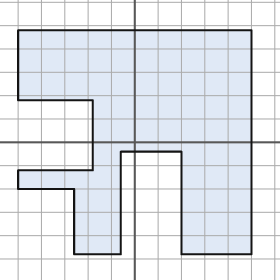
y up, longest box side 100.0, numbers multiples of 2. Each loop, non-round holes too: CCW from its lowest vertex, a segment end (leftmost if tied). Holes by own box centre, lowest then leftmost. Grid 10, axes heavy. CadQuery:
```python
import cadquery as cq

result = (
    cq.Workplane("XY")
    .moveTo(-26.0, -48.0)
    .lineTo(-6.0, -48.0)
    .lineTo(-6.0, -4.0)
    .lineTo(20.0, -4.0)
    .lineTo(20.0, -48.0)
    .lineTo(50.0, -48.0)
    .lineTo(50.0, 48.0)
    .lineTo(-50.0, 48.0)
    .lineTo(-50.0, 18.0)
    .lineTo(-18.0, 18.0)
    .lineTo(-18.0, -12.0)
    .lineTo(-50.0, -12.0)
    .lineTo(-50.0, -20.0)
    .lineTo(-26.0, -20.0)
    .close()
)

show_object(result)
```